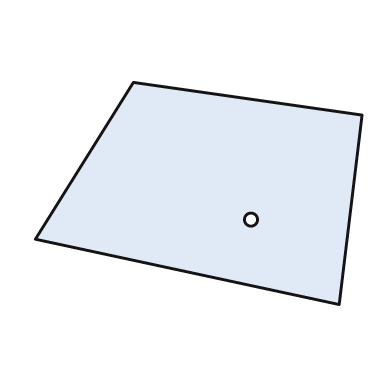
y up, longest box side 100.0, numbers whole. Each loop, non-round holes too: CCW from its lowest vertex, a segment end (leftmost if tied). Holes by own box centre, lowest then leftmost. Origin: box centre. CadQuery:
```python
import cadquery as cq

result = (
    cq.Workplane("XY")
    .moveTo(43.0, -34.0)
    .lineTo(50.0, 24.0)
    .lineTo(-20.0, 34.0)
    .lineTo(-50.0, -14.0)
    .close()
    .moveTo(16.0, -8.0)
    .circle(2.0)
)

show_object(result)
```